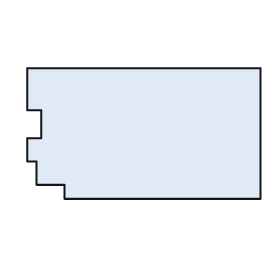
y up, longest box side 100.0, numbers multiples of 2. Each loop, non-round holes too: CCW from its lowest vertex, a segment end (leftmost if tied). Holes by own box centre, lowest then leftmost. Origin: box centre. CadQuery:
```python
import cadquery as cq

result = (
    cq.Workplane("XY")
    .moveTo(-34.0, -28.0)
    .lineTo(50.0, -28.0)
    .lineTo(50.0, 28.0)
    .lineTo(-50.0, 28.0)
    .lineTo(-50.0, 10.0)
    .lineTo(-44.0, 10.0)
    .lineTo(-44.0, -2.0)
    .lineTo(-50.0, -2.0)
    .lineTo(-50.0, -12.0)
    .lineTo(-46.0, -12.0)
    .lineTo(-46.0, -22.0)
    .lineTo(-34.0, -22.0)
    .close()
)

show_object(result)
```